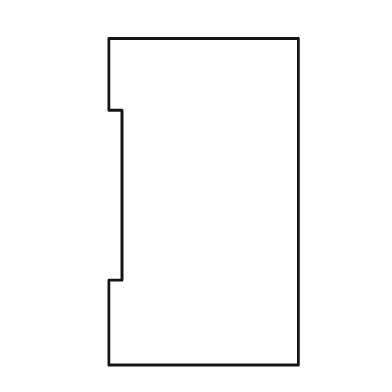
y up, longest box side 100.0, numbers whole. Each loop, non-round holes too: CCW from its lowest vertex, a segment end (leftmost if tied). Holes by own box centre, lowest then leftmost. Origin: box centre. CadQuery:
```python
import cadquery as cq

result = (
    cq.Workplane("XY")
    .moveTo(-29.0, -50.0)
    .lineTo(29.0, -50.0)
    .lineTo(29.0, 50.0)
    .lineTo(-29.0, 50.0)
    .lineTo(-29.0, 28.0)
    .lineTo(-25.0, 28.0)
    .lineTo(-25.0, -24.0)
    .lineTo(-29.0, -24.0)
    .close()
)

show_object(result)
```